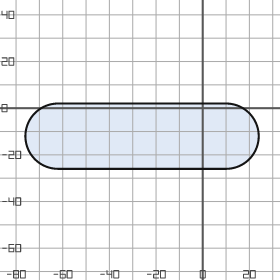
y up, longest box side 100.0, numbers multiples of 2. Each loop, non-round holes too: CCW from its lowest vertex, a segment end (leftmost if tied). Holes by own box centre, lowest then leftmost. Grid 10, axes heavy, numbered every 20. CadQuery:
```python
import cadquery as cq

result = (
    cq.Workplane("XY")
    .moveTo(-62.0, -26.0)
    .lineTo(10.0, -26.0)
    .threePointArc((24.0, -12.0), (10.0, 2.0))
    .lineTo(-62.0, 2.0)
    .threePointArc((-76.0, -12.0), (-62.0, -26.0))
    .close()
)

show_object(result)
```